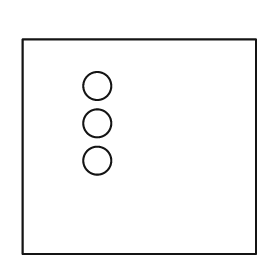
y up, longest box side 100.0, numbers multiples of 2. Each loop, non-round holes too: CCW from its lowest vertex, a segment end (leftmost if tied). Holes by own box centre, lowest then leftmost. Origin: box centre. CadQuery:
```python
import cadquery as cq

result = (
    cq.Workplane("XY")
    .moveTo(-50.0, -46.0)
    .lineTo(50.0, -46.0)
    .lineTo(50.0, 46.0)
    .lineTo(-50.0, 46.0)
    .close()
    .moveTo(-18.0, -6.0)
    .circle(6.0)
    .moveTo(-18.0, 10.0)
    .circle(6.0)
    .moveTo(-18.0, 26.0)
    .circle(6.0)
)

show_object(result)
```